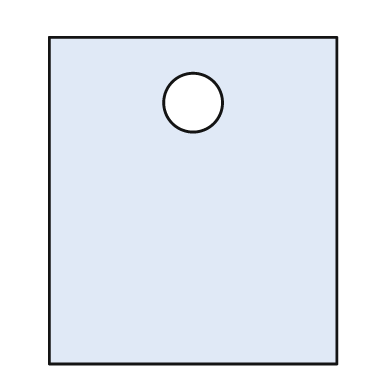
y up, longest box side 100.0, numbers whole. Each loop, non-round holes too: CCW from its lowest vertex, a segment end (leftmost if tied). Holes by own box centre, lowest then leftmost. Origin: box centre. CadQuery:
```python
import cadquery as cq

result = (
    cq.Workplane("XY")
    .moveTo(-44.0, -50.0)
    .lineTo(44.0, -50.0)
    .lineTo(44.0, 50.0)
    .lineTo(-44.0, 50.0)
    .close()
    .moveTo(0.0, 30.0)
    .circle(9.0)
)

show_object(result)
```